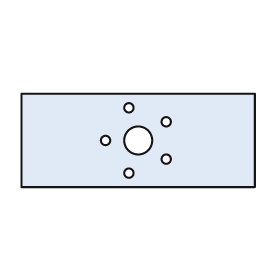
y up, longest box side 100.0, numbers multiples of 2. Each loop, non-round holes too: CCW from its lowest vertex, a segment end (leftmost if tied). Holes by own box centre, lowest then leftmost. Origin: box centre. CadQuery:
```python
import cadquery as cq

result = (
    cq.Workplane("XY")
    .moveTo(-50.0, -20.0)
    .lineTo(50.0, -20.0)
    .lineTo(50.0, 20.0)
    .lineTo(-50.0, 20.0)
    .close()
    .moveTo(-4.0, -14.0)
    .circle(2.0)
    .moveTo(12.0, -8.0)
    .circle(2.0)
    .moveTo(-14.0, 0.0)
    .circle(2.0)
    .moveTo(0.0, 0.0)
    .circle(6.0)
    .moveTo(12.0, 8.0)
    .circle(2.0)
    .moveTo(-4.0, 14.0)
    .circle(2.0)
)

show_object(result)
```